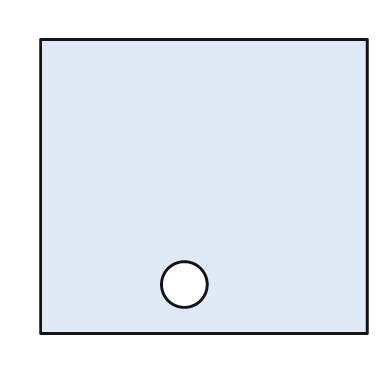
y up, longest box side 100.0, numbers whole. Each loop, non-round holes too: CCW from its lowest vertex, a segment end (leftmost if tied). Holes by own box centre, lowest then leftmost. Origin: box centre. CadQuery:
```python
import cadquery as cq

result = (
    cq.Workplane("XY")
    .moveTo(-50.0, -45.0)
    .lineTo(50.0, -45.0)
    .lineTo(50.0, 45.0)
    .lineTo(-50.0, 45.0)
    .close()
    .moveTo(-6.0, -30.0)
    .circle(7.0)
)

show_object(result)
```